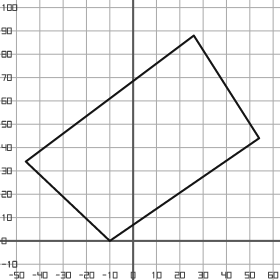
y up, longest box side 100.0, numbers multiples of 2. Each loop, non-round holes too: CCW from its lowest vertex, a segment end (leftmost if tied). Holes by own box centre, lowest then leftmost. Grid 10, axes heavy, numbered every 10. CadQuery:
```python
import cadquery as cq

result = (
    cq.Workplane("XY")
    .moveTo(-10.0, 0.0)
    .lineTo(54.0, 44.0)
    .lineTo(26.0, 88.0)
    .lineTo(-46.0, 34.0)
    .close()
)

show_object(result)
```